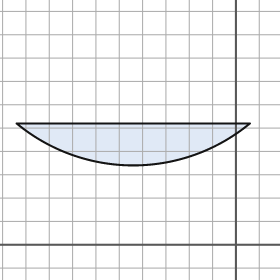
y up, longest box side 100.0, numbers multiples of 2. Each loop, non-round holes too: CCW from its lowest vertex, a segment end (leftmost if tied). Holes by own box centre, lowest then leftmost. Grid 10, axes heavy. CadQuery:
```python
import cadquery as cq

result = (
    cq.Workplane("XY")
    .moveTo(-94.0, 52.0)
    .threePointArc((-44.0, 34.0), (6.0, 52.0))
    .close()
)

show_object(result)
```